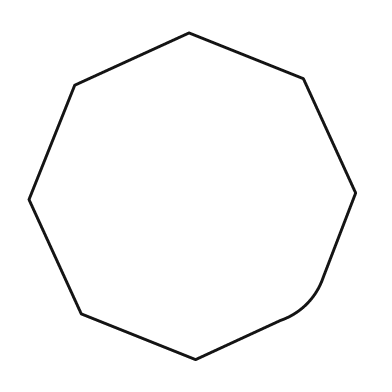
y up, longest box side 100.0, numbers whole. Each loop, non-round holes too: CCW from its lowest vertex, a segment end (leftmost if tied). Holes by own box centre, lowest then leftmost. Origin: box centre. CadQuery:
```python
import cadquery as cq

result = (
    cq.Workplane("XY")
    .moveTo(1.0, -50.0)
    .lineTo(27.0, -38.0)
    .threePointArc((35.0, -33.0), (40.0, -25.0))
    .lineTo(50.0, 1.0)
    .lineTo(34.0, 36.0)
    .lineTo(-1.0, 50.0)
    .lineTo(-36.0, 34.0)
    .lineTo(-50.0, -1.0)
    .lineTo(-34.0, -36.0)
    .close()
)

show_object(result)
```